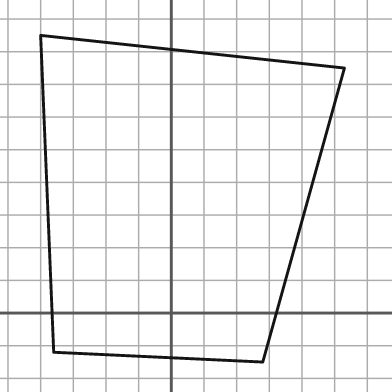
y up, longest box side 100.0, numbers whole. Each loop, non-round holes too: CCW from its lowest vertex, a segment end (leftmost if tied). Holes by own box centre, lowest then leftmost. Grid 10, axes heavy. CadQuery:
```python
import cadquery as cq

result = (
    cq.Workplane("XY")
    .moveTo(28.0, -15.0)
    .lineTo(53.0, 75.0)
    .lineTo(-40.0, 85.0)
    .lineTo(-36.0, -12.0)
    .close()
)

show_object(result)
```